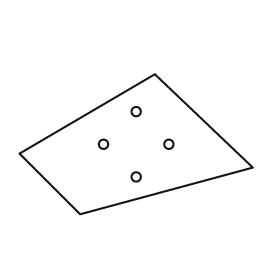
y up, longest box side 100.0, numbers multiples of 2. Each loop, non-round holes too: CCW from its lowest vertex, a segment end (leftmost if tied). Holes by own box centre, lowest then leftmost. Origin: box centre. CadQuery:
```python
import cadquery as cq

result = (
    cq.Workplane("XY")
    .moveTo(-24.0, -30.0)
    .lineTo(50.0, -10.0)
    .lineTo(8.0, 30.0)
    .lineTo(-50.0, -4.0)
    .close()
    .moveTo(0.0, -14.0)
    .circle(2.0)
    .moveTo(-14.0, 0.0)
    .circle(2.0)
    .moveTo(14.0, 0.0)
    .circle(2.0)
    .moveTo(0.0, 14.0)
    .circle(2.0)
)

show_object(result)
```